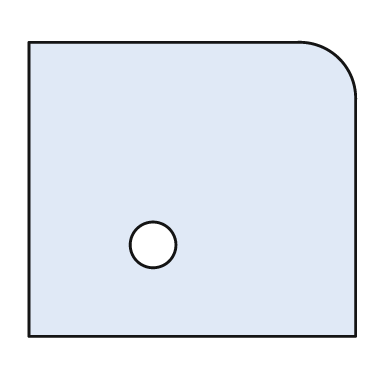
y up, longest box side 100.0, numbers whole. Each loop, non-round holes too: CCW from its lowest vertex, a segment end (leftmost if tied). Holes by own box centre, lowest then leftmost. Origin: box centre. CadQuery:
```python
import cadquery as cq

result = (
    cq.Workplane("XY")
    .moveTo(-50.0, -45.0)
    .lineTo(50.0, -45.0)
    .lineTo(50.0, 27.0)
    .threePointArc((45.0, 40.0), (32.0, 45.0))
    .lineTo(-50.0, 45.0)
    .close()
    .moveTo(-12.0, -17.0)
    .circle(7.0)
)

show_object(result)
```